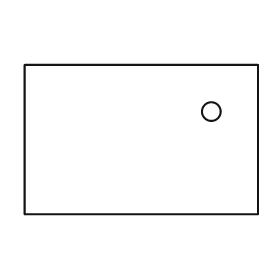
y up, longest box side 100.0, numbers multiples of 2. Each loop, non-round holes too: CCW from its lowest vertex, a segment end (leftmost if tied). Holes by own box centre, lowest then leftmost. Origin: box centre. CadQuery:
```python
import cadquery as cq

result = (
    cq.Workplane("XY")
    .moveTo(-50.0, -32.0)
    .lineTo(50.0, -32.0)
    .lineTo(50.0, 32.0)
    .lineTo(-50.0, 32.0)
    .close()
    .moveTo(30.0, 12.0)
    .circle(4.0)
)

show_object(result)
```